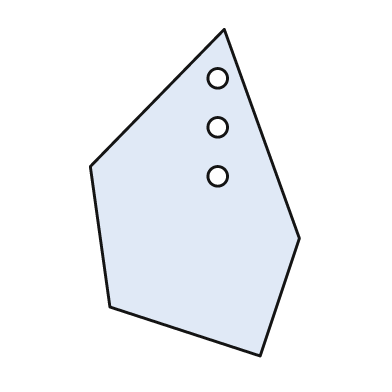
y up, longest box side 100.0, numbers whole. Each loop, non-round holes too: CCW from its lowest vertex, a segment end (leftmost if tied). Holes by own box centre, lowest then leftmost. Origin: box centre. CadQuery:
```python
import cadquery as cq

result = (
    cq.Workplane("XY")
    .moveTo(20.0, -50.0)
    .lineTo(32.0, -14.0)
    .lineTo(9.0, 50.0)
    .lineTo(-32.0, 8.0)
    .lineTo(-26.0, -35.0)
    .close()
    .moveTo(7.0, 5.0)
    .circle(3.0)
    .moveTo(7.0, 20.0)
    .circle(3.0)
    .moveTo(7.0, 35.0)
    .circle(3.0)
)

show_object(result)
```